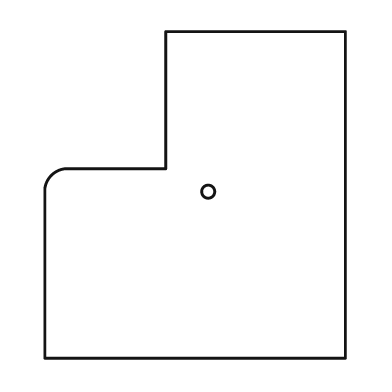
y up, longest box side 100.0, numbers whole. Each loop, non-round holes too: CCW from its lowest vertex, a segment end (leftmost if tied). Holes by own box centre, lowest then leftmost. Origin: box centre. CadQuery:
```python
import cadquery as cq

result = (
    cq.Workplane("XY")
    .moveTo(-46.0, -50.0)
    .lineTo(46.0, -50.0)
    .lineTo(46.0, 50.0)
    .lineTo(-9.0, 50.0)
    .lineTo(-9.0, 8.0)
    .lineTo(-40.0, 8.0)
    .threePointArc((-44.0, 6.0), (-46.0, 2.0))
    .close()
    .moveTo(4.0, 1.0)
    .circle(2.0)
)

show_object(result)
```